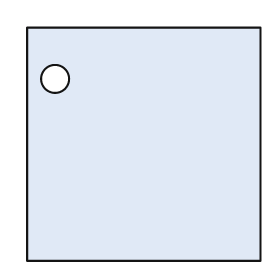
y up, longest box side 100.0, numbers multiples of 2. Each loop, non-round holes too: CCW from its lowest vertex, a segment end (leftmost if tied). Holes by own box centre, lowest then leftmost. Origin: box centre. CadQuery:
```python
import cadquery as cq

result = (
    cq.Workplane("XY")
    .moveTo(-50.0, -50.0)
    .lineTo(50.0, -50.0)
    .lineTo(50.0, 50.0)
    .lineTo(-50.0, 50.0)
    .close()
    .moveTo(-38.0, 28.0)
    .circle(6.0)
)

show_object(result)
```